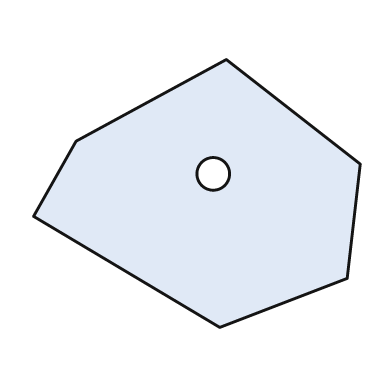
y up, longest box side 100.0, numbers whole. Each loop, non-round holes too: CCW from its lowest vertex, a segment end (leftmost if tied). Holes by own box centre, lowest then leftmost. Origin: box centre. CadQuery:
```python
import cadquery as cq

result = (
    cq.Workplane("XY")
    .moveTo(7.0, -41.0)
    .lineTo(46.0, -26.0)
    .lineTo(50.0, 9.0)
    .lineTo(9.0, 41.0)
    .lineTo(-37.0, 16.0)
    .lineTo(-50.0, -7.0)
    .close()
    .moveTo(5.0, 6.0)
    .circle(5.0)
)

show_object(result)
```